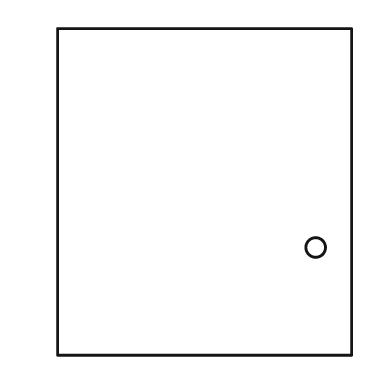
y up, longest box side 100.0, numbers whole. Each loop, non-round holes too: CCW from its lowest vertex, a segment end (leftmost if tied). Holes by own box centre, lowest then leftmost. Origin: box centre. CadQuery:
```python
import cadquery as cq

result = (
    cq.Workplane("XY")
    .moveTo(-45.0, -50.0)
    .lineTo(45.0, -50.0)
    .lineTo(45.0, 50.0)
    .lineTo(-45.0, 50.0)
    .close()
    .moveTo(34.0, -17.0)
    .circle(3.0)
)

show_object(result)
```